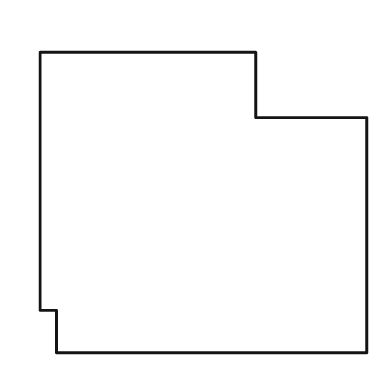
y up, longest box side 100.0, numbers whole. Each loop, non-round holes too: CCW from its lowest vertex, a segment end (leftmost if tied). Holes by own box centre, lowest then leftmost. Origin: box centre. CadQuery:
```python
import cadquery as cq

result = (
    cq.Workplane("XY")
    .moveTo(-45.0, -46.0)
    .lineTo(50.0, -46.0)
    .lineTo(50.0, 26.0)
    .lineTo(16.0, 26.0)
    .lineTo(16.0, 46.0)
    .lineTo(-50.0, 46.0)
    .lineTo(-50.0, -33.0)
    .lineTo(-45.0, -33.0)
    .close()
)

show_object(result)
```